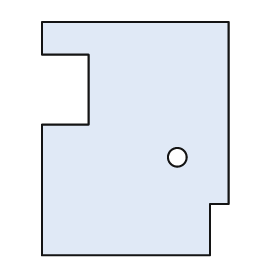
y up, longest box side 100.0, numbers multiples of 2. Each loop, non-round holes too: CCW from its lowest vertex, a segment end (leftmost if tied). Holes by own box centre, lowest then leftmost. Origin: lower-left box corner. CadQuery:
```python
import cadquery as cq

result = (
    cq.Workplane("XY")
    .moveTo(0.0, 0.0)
    .lineTo(72.0, 0.0)
    .lineTo(72.0, 22.0)
    .lineTo(80.0, 22.0)
    .lineTo(80.0, 100.0)
    .lineTo(0.0, 100.0)
    .lineTo(0.0, 86.0)
    .lineTo(20.0, 86.0)
    .lineTo(20.0, 56.0)
    .lineTo(0.0, 56.0)
    .close()
    .moveTo(58.0, 42.0)
    .circle(4.0)
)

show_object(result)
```